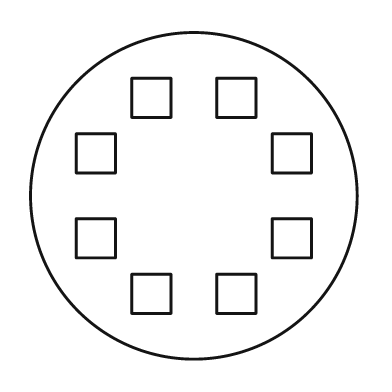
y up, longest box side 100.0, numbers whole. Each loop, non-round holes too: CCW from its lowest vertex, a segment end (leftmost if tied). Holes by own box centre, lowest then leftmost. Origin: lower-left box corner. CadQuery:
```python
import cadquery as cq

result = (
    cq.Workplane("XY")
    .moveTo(50.0, 50.0)
    .circle(50.0)
    .moveTo(31.0, 14.0)
    .lineTo(43.0, 14.0)
    .lineTo(43.0, 26.0)
    .lineTo(31.0, 26.0)
    .close()
    .moveTo(57.0, 14.0)
    .lineTo(69.0, 14.0)
    .lineTo(69.0, 26.0)
    .lineTo(57.0, 26.0)
    .close()
    .moveTo(14.0, 31.0)
    .lineTo(26.0, 31.0)
    .lineTo(26.0, 43.0)
    .lineTo(14.0, 43.0)
    .close()
    .moveTo(74.0, 31.0)
    .lineTo(86.0, 31.0)
    .lineTo(86.0, 43.0)
    .lineTo(74.0, 43.0)
    .close()
    .moveTo(14.0, 57.0)
    .lineTo(26.0, 57.0)
    .lineTo(26.0, 69.0)
    .lineTo(14.0, 69.0)
    .close()
    .moveTo(74.0, 57.0)
    .lineTo(86.0, 57.0)
    .lineTo(86.0, 69.0)
    .lineTo(74.0, 69.0)
    .close()
    .moveTo(31.0, 74.0)
    .lineTo(43.0, 74.0)
    .lineTo(43.0, 86.0)
    .lineTo(31.0, 86.0)
    .close()
    .moveTo(57.0, 74.0)
    .lineTo(69.0, 74.0)
    .lineTo(69.0, 86.0)
    .lineTo(57.0, 86.0)
    .close()
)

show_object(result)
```